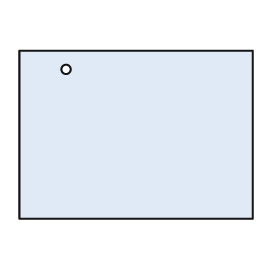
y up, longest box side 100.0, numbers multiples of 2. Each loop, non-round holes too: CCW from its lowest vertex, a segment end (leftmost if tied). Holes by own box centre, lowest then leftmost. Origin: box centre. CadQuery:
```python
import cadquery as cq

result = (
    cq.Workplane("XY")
    .moveTo(-50.0, -36.0)
    .lineTo(50.0, -36.0)
    .lineTo(50.0, 36.0)
    .lineTo(-50.0, 36.0)
    .close()
    .moveTo(-30.0, 28.0)
    .circle(2.0)
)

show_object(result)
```